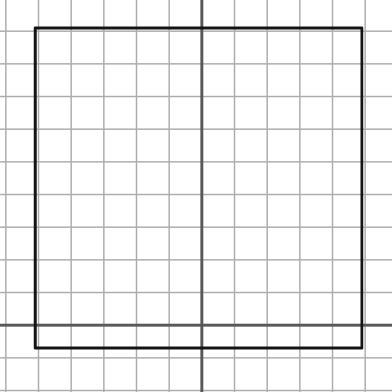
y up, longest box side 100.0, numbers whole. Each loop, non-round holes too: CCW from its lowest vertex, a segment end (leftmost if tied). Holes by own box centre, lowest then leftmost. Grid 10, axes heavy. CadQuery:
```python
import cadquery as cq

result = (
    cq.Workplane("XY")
    .moveTo(-51.0, -7.0)
    .lineTo(49.0, -7.0)
    .lineTo(49.0, 91.0)
    .lineTo(-51.0, 91.0)
    .close()
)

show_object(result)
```